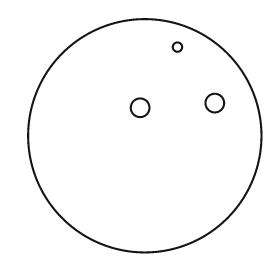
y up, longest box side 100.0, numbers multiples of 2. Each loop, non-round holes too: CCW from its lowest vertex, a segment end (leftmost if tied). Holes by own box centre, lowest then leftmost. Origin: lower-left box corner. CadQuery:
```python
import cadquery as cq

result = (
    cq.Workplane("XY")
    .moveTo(50.0, 50.0)
    .circle(50.0)
    .moveTo(48.0, 62.0)
    .circle(4.0)
    .moveTo(80.0, 64.0)
    .circle(4.0)
    .moveTo(64.0, 88.0)
    .circle(2.0)
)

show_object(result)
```